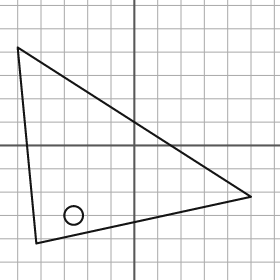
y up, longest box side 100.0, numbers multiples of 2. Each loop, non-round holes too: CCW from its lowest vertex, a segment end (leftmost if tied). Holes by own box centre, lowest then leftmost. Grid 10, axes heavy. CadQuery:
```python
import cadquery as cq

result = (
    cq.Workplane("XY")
    .moveTo(-42.0, -42.0)
    .lineTo(50.0, -22.0)
    .lineTo(-50.0, 42.0)
    .close()
    .moveTo(-26.0, -30.0)
    .circle(4.0)
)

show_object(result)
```